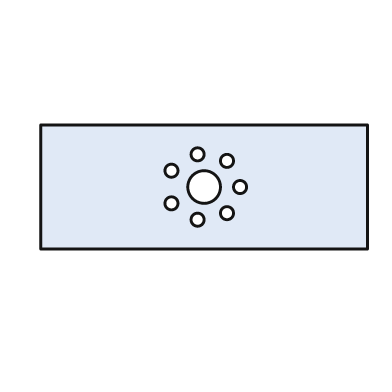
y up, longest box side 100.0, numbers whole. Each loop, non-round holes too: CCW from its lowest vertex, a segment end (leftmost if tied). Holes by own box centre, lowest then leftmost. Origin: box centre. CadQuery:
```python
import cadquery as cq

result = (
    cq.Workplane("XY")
    .moveTo(-50.0, -19.0)
    .lineTo(50.0, -19.0)
    .lineTo(50.0, 19.0)
    .lineTo(-50.0, 19.0)
    .close()
    .moveTo(-2.0, -10.0)
    .circle(2.0)
    .moveTo(7.0, -8.0)
    .circle(2.0)
    .moveTo(-10.0, -5.0)
    .circle(2.0)
    .moveTo(0.0, 0.0)
    .circle(5.0)
    .moveTo(11.0, 0.0)
    .circle(2.0)
    .moveTo(-10.0, 5.0)
    .circle(2.0)
    .moveTo(7.0, 8.0)
    .circle(2.0)
    .moveTo(-2.0, 10.0)
    .circle(2.0)
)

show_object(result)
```